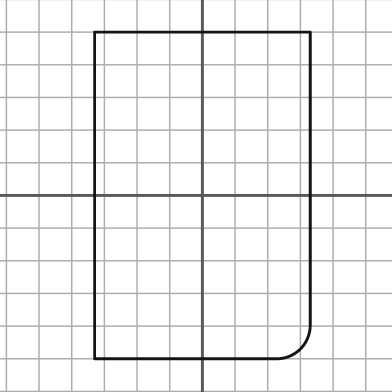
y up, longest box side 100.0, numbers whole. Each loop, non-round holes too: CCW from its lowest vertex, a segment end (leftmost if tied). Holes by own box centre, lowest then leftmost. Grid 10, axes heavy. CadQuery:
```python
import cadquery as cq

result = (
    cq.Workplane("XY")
    .moveTo(-33.0, -50.0)
    .lineTo(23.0, -50.0)
    .threePointArc((30.0, -47.0), (33.0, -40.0))
    .lineTo(33.0, 50.0)
    .lineTo(-33.0, 50.0)
    .close()
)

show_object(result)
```